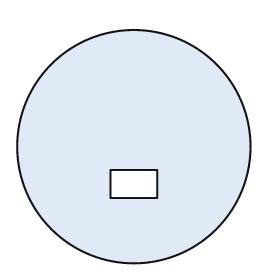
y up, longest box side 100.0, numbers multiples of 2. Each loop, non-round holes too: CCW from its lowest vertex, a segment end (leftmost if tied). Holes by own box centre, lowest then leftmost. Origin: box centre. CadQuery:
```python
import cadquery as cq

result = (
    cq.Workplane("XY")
    .moveTo(0.0, 0.0)
    .circle(50.0)
    .moveTo(-10.0, -22.0)
    .lineTo(10.0, -22.0)
    .lineTo(10.0, -10.0)
    .lineTo(-10.0, -10.0)
    .close()
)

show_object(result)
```